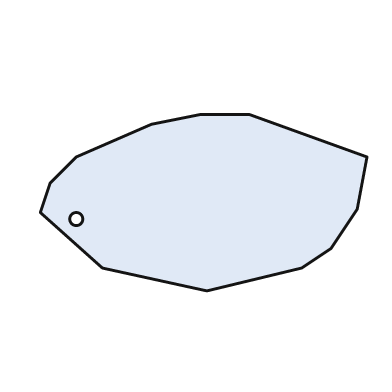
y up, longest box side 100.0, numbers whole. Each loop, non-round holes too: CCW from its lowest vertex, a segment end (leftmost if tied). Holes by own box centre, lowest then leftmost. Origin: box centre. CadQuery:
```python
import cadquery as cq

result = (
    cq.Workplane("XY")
    .moveTo(1.0, -27.0)
    .lineTo(30.0, -20.0)
    .lineTo(39.0, -14.0)
    .lineTo(47.0, -2.0)
    .lineTo(50.0, 14.0)
    .lineTo(14.0, 27.0)
    .lineTo(-1.0, 27.0)
    .lineTo(-16.0, 24.0)
    .lineTo(-39.0, 14.0)
    .lineTo(-47.0, 6.0)
    .lineTo(-50.0, -3.0)
    .lineTo(-31.0, -20.0)
    .close()
    .moveTo(-39.0, -5.0)
    .circle(2.0)
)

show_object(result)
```